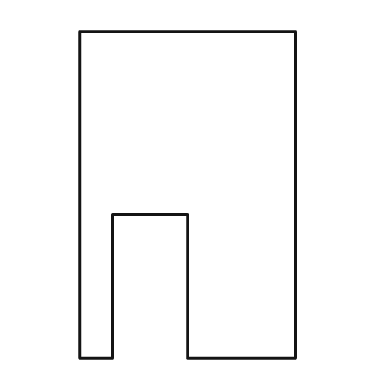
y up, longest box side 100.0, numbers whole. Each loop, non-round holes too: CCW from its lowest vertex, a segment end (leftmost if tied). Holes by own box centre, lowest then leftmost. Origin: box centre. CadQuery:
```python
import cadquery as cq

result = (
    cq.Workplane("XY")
    .moveTo(-33.0, -50.0)
    .lineTo(-23.0, -50.0)
    .lineTo(-23.0, -6.0)
    .lineTo(0.0, -6.0)
    .lineTo(0.0, -50.0)
    .lineTo(33.0, -50.0)
    .lineTo(33.0, 50.0)
    .lineTo(-33.0, 50.0)
    .close()
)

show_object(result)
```